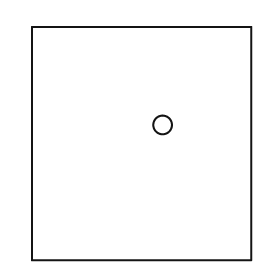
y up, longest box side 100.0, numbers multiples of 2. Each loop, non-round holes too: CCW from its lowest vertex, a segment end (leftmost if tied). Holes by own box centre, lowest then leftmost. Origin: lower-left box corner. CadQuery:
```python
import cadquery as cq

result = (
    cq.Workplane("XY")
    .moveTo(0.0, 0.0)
    .lineTo(94.0, 0.0)
    .lineTo(94.0, 100.0)
    .lineTo(0.0, 100.0)
    .close()
    .moveTo(56.0, 58.0)
    .circle(4.0)
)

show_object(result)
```